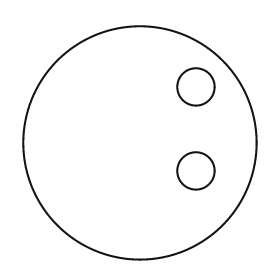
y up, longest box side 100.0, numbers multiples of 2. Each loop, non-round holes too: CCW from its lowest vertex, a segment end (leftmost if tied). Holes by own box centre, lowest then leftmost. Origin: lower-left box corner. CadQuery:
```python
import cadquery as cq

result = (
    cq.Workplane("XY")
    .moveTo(50.0, 50.0)
    .circle(50.0)
    .moveTo(74.0, 38.0)
    .circle(8.0)
    .moveTo(74.0, 74.0)
    .circle(8.0)
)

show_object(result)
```